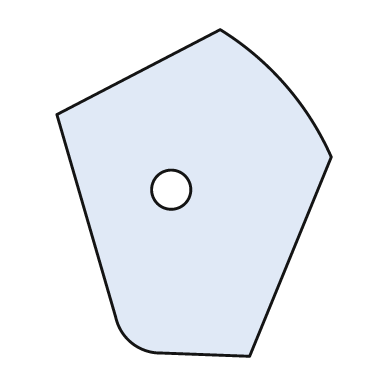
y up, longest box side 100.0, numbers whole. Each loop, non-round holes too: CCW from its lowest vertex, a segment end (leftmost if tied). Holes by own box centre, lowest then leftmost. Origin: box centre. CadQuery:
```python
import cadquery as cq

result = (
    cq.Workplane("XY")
    .moveTo(17.0, -50.0)
    .lineTo(42.0, 11.0)
    .threePointArc((28.0, 33.0), (8.0, 50.0))
    .lineTo(-42.0, 24.0)
    .lineTo(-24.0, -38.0)
    .threePointArc((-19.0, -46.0), (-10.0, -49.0))
    .close()
    .moveTo(-7.0, 1.0)
    .circle(6.0)
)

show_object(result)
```